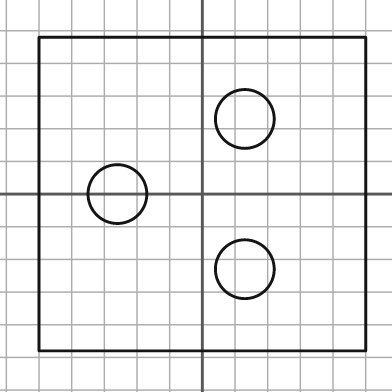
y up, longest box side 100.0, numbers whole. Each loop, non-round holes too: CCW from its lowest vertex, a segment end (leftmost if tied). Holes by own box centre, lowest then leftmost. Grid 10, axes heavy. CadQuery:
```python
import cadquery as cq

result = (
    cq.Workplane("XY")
    .moveTo(-50.0, -48.0)
    .lineTo(50.0, -48.0)
    .lineTo(50.0, 48.0)
    .lineTo(-50.0, 48.0)
    .close()
    .moveTo(13.0, -23.0)
    .circle(9.0)
    .moveTo(-26.0, 0.0)
    .circle(9.0)
    .moveTo(13.0, 23.0)
    .circle(9.0)
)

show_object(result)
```